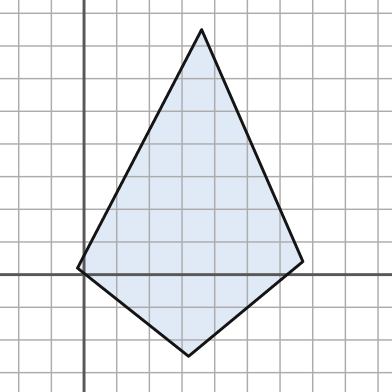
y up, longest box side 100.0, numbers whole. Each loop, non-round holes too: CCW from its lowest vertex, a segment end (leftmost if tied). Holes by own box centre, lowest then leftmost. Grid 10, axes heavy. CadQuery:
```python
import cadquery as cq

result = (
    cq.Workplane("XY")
    .moveTo(32.0, -25.0)
    .lineTo(67.0, 4.0)
    .lineTo(36.0, 75.0)
    .lineTo(-2.0, 2.0)
    .close()
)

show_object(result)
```